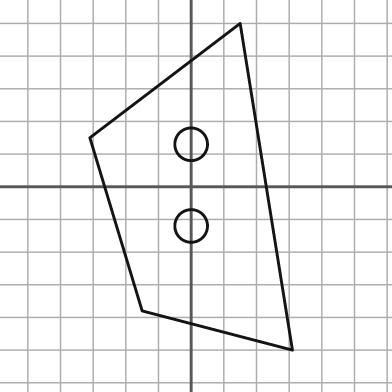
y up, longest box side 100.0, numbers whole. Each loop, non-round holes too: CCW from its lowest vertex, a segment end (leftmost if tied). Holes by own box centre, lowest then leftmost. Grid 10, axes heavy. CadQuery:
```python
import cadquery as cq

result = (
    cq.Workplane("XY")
    .moveTo(31.0, -50.0)
    .lineTo(15.0, 50.0)
    .lineTo(-31.0, 15.0)
    .lineTo(-15.0, -38.0)
    .close()
    .moveTo(0.0, -12.0)
    .circle(5.0)
    .moveTo(0.0, 13.0)
    .circle(5.0)
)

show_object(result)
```